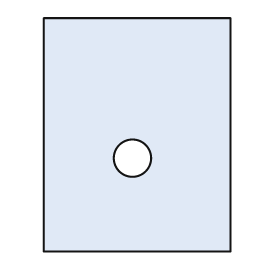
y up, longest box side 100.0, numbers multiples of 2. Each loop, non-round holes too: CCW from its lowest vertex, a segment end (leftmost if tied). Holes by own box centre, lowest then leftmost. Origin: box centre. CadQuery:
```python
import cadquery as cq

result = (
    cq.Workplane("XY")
    .moveTo(-40.0, -50.0)
    .lineTo(40.0, -50.0)
    .lineTo(40.0, 50.0)
    .lineTo(-40.0, 50.0)
    .close()
    .moveTo(-2.0, -10.0)
    .circle(8.0)
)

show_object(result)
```